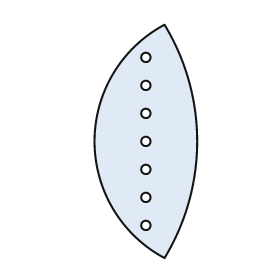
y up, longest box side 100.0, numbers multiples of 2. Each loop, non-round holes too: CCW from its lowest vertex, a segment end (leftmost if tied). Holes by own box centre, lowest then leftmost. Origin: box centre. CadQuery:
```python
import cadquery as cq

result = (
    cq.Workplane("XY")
    .moveTo(8.0, -50.0)
    .threePointArc((22.0, 0.0), (8.0, 50.0))
    .threePointArc((-22.0, 0.0), (8.0, -50.0))
    .close()
    .moveTo(0.0, -36.0)
    .circle(2.0)
    .moveTo(0.0, -24.0)
    .circle(2.0)
    .moveTo(0.0, -12.0)
    .circle(2.0)
    .moveTo(0.0, 0.0)
    .circle(2.0)
    .moveTo(0.0, 12.0)
    .circle(2.0)
    .moveTo(0.0, 24.0)
    .circle(2.0)
    .moveTo(0.0, 36.0)
    .circle(2.0)
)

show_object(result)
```